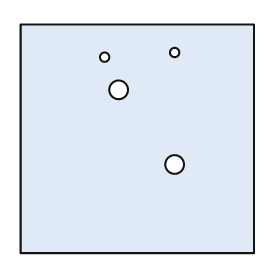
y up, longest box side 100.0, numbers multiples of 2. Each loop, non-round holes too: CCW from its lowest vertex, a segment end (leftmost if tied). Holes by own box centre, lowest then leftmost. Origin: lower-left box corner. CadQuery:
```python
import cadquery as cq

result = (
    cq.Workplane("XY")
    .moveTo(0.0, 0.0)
    .lineTo(100.0, 0.0)
    .lineTo(100.0, 98.0)
    .lineTo(0.0, 98.0)
    .close()
    .moveTo(66.0, 38.0)
    .circle(4.0)
    .moveTo(42.0, 70.0)
    .circle(4.0)
    .moveTo(36.0, 84.0)
    .circle(2.0)
    .moveTo(66.0, 86.0)
    .circle(2.0)
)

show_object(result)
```